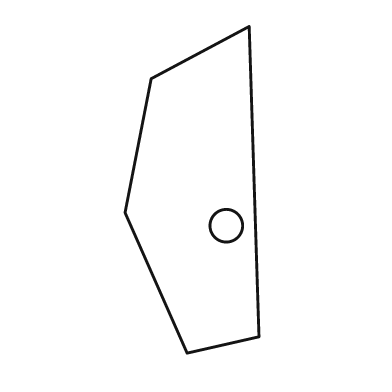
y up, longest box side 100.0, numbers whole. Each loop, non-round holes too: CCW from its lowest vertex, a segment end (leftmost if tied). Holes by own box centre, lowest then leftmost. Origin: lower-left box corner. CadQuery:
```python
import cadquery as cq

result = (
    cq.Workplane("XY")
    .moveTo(19.0, 0.0)
    .lineTo(41.0, 5.0)
    .lineTo(38.0, 100.0)
    .lineTo(8.0, 84.0)
    .lineTo(0.0, 43.0)
    .close()
    .moveTo(31.0, 39.0)
    .circle(5.0)
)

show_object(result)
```